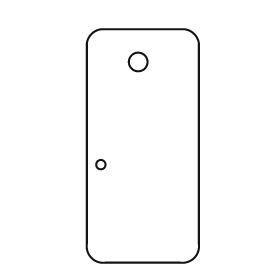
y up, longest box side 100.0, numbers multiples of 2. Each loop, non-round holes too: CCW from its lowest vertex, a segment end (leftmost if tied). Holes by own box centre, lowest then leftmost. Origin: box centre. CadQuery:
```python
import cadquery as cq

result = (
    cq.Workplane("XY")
    .moveTo(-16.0, -50.0)
    .lineTo(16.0, -50.0)
    .threePointArc((22.0, -48.0), (24.0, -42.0))
    .lineTo(24.0, 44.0)
    .threePointArc((22.0, 48.0), (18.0, 50.0))
    .lineTo(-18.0, 50.0)
    .threePointArc((-22.0, 48.0), (-24.0, 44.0))
    .lineTo(-24.0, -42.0)
    .threePointArc((-22.0, -48.0), (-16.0, -50.0))
    .close()
    .moveTo(-18.0, -8.0)
    .circle(2.0)
    .moveTo(-2.0, 36.0)
    .circle(4.0)
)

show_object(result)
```